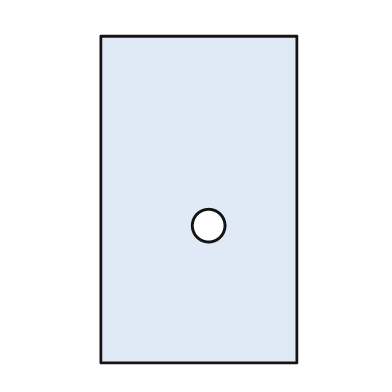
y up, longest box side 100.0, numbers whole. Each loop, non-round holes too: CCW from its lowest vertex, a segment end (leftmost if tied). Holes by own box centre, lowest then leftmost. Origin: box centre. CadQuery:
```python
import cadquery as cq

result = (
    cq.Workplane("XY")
    .moveTo(-30.0, -50.0)
    .lineTo(30.0, -50.0)
    .lineTo(30.0, 50.0)
    .lineTo(-30.0, 50.0)
    .close()
    .moveTo(3.0, -8.0)
    .circle(5.0)
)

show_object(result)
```